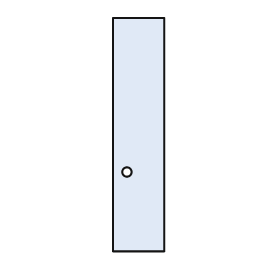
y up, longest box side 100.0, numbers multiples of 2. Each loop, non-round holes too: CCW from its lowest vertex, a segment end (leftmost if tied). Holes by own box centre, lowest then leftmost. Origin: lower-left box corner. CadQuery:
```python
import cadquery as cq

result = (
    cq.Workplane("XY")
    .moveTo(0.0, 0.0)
    .lineTo(22.0, 0.0)
    .lineTo(22.0, 100.0)
    .lineTo(0.0, 100.0)
    .close()
    .moveTo(6.0, 34.0)
    .circle(2.0)
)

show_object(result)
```